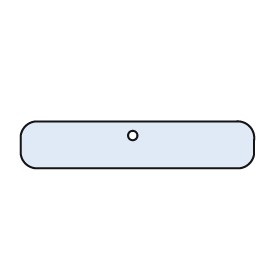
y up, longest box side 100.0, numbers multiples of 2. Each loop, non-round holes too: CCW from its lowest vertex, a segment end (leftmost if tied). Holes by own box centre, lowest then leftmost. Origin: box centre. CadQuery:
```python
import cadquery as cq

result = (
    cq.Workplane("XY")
    .moveTo(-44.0, -10.0)
    .lineTo(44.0, -10.0)
    .threePointArc((48.0, -8.0), (50.0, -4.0))
    .lineTo(50.0, 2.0)
    .threePointArc((48.0, 8.0), (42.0, 10.0))
    .lineTo(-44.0, 10.0)
    .threePointArc((-48.0, 8.0), (-50.0, 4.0))
    .lineTo(-50.0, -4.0)
    .threePointArc((-48.0, -8.0), (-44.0, -10.0))
    .close()
    .moveTo(-2.0, 4.0)
    .circle(2.0)
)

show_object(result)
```